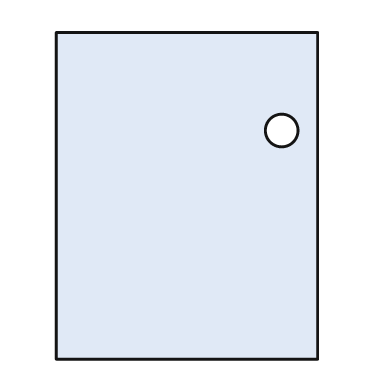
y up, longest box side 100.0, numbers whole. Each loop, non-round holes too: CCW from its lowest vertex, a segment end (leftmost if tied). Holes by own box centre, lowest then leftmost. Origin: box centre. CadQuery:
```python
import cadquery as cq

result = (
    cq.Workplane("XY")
    .moveTo(-40.0, -50.0)
    .lineTo(40.0, -50.0)
    .lineTo(40.0, 50.0)
    .lineTo(-40.0, 50.0)
    .close()
    .moveTo(29.0, 20.0)
    .circle(5.0)
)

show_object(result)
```